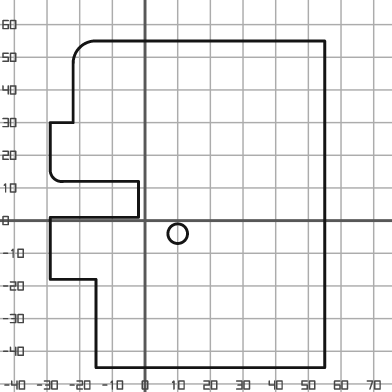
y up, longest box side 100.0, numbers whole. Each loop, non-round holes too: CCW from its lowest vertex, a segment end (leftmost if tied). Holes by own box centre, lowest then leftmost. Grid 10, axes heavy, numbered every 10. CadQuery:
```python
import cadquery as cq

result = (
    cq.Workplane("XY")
    .moveTo(-15.0, -45.0)
    .lineTo(55.0, -45.0)
    .lineTo(55.0, 55.0)
    .lineTo(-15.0, 55.0)
    .threePointArc((-20.0, 53.0), (-22.0, 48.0))
    .lineTo(-22.0, 30.0)
    .lineTo(-29.0, 30.0)
    .lineTo(-29.0, 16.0)
    .threePointArc((-28.0, 13.0), (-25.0, 12.0))
    .lineTo(-2.0, 12.0)
    .lineTo(-2.0, 1.0)
    .lineTo(-29.0, 1.0)
    .lineTo(-29.0, -18.0)
    .lineTo(-15.0, -18.0)
    .close()
    .moveTo(10.0, -4.0)
    .circle(3.0)
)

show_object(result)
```